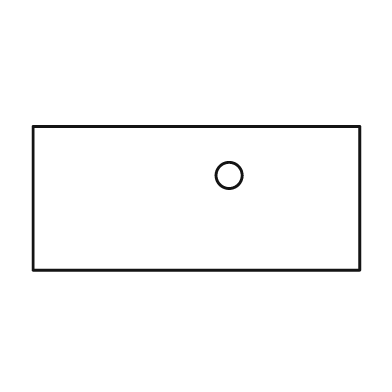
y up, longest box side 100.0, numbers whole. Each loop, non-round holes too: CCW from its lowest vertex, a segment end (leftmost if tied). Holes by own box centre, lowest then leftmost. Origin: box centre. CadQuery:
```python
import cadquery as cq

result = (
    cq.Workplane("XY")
    .moveTo(-50.0, -22.0)
    .lineTo(50.0, -22.0)
    .lineTo(50.0, 22.0)
    .lineTo(-50.0, 22.0)
    .close()
    .moveTo(10.0, 7.0)
    .circle(4.0)
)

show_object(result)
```